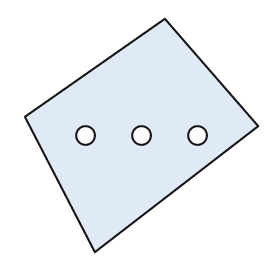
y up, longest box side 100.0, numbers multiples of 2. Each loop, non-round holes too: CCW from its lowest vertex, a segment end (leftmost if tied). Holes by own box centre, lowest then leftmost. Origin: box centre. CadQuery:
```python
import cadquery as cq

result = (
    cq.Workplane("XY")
    .moveTo(-20.0, -50.0)
    .lineTo(50.0, 4.0)
    .lineTo(10.0, 50.0)
    .lineTo(-50.0, 8.0)
    .close()
    .moveTo(-24.0, 0.0)
    .circle(4.0)
    .moveTo(0.0, 0.0)
    .circle(4.0)
    .moveTo(24.0, 0.0)
    .circle(4.0)
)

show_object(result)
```